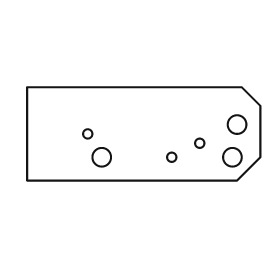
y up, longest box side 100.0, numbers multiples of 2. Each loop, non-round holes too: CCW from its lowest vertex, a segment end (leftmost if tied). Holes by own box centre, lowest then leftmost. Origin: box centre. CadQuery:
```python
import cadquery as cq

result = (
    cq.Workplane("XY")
    .moveTo(-50.0, -20.0)
    .lineTo(40.0, -20.0)
    .lineTo(50.0, -10.0)
    .lineTo(50.0, 12.0)
    .lineTo(42.0, 20.0)
    .lineTo(-50.0, 20.0)
    .close()
    .moveTo(-18.0, -10.0)
    .circle(4.0)
    .moveTo(12.0, -10.0)
    .circle(2.0)
    .moveTo(38.0, -10.0)
    .circle(4.0)
    .moveTo(24.0, -4.0)
    .circle(2.0)
    .moveTo(-24.0, 0.0)
    .circle(2.0)
    .moveTo(40.0, 4.0)
    .circle(4.0)
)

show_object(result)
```